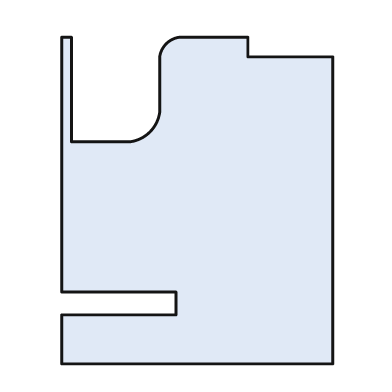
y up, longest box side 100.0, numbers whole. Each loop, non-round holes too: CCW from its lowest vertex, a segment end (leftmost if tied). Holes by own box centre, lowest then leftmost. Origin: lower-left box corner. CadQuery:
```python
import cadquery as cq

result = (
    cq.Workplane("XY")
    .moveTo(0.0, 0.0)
    .lineTo(83.0, 0.0)
    .lineTo(83.0, 94.0)
    .lineTo(57.0, 94.0)
    .lineTo(57.0, 100.0)
    .lineTo(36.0, 100.0)
    .threePointArc((32.0, 98.0), (30.0, 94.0))
    .lineTo(30.0, 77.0)
    .threePointArc((27.0, 71.0), (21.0, 68.0))
    .lineTo(3.0, 68.0)
    .lineTo(3.0, 100.0)
    .lineTo(0.0, 100.0)
    .lineTo(0.0, 22.0)
    .lineTo(35.0, 22.0)
    .lineTo(35.0, 15.0)
    .lineTo(0.0, 15.0)
    .close()
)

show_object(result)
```